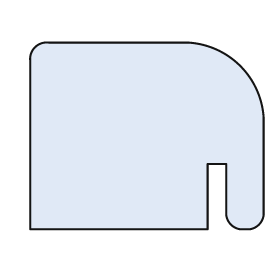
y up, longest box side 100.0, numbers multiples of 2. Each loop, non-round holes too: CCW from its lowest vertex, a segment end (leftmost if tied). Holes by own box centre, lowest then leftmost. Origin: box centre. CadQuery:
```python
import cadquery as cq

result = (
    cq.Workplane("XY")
    .moveTo(-50.0, -40.0)
    .lineTo(26.0, -40.0)
    .lineTo(26.0, -12.0)
    .lineTo(34.0, -12.0)
    .lineTo(34.0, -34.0)
    .threePointArc((36.0, -38.0), (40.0, -40.0))
    .lineTo(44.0, -40.0)
    .threePointArc((48.0, -38.0), (50.0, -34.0))
    .lineTo(50.0, 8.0)
    .threePointArc((40.0, 30.0), (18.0, 40.0))
    .lineTo(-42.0, 40.0)
    .threePointArc((-48.0, 38.0), (-50.0, 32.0))
    .close()
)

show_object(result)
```